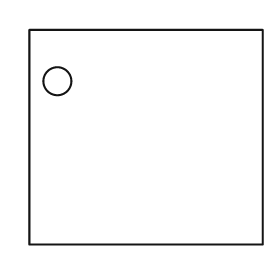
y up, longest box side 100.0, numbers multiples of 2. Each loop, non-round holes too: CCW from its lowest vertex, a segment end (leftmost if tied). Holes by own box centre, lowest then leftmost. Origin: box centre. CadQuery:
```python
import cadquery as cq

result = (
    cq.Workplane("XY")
    .moveTo(-50.0, -46.0)
    .lineTo(50.0, -46.0)
    .lineTo(50.0, 46.0)
    .lineTo(-50.0, 46.0)
    .close()
    .moveTo(-38.0, 24.0)
    .circle(6.0)
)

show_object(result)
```